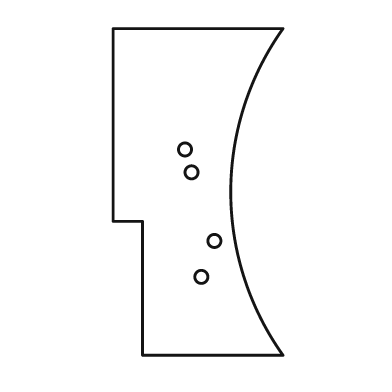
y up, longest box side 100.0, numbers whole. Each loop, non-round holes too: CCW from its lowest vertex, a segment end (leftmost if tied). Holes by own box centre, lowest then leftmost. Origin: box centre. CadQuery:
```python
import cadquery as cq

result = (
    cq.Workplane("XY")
    .moveTo(-17.0, -50.0)
    .lineTo(26.0, -50.0)
    .threePointArc((10.0, 0.0), (26.0, 50.0))
    .lineTo(-26.0, 50.0)
    .lineTo(-26.0, -9.0)
    .lineTo(-17.0, -9.0)
    .close()
    .moveTo(1.0, -26.0)
    .circle(2.0)
    .moveTo(5.0, -15.0)
    .circle(2.0)
    .moveTo(-2.0, 6.0)
    .circle(2.0)
    .moveTo(-4.0, 13.0)
    .circle(2.0)
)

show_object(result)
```